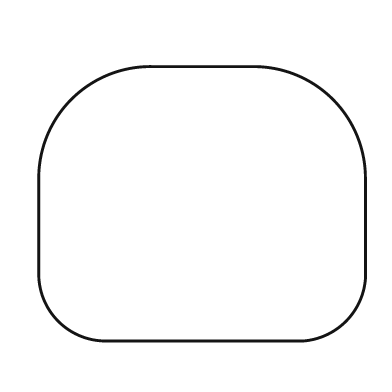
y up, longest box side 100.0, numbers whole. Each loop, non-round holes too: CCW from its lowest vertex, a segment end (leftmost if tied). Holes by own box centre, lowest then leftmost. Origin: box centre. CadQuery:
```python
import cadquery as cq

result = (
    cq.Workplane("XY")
    .moveTo(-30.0, -42.0)
    .lineTo(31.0, -42.0)
    .threePointArc((44.0, -36.0), (50.0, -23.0))
    .lineTo(50.0, 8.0)
    .threePointArc((40.0, 32.0), (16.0, 42.0))
    .lineTo(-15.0, 42.0)
    .threePointArc((-40.0, 32.0), (-50.0, 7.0))
    .lineTo(-50.0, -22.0)
    .threePointArc((-44.0, -36.0), (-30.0, -42.0))
    .close()
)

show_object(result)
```